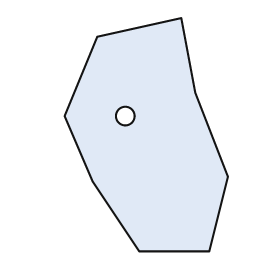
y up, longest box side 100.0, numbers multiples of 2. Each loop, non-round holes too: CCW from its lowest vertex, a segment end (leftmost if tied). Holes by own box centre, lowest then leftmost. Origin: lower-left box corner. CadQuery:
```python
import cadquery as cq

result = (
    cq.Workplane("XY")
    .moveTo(32.0, 0.0)
    .lineTo(62.0, 0.0)
    .lineTo(70.0, 32.0)
    .lineTo(56.0, 68.0)
    .lineTo(50.0, 100.0)
    .lineTo(14.0, 92.0)
    .lineTo(0.0, 58.0)
    .lineTo(12.0, 30.0)
    .close()
    .moveTo(26.0, 58.0)
    .circle(4.0)
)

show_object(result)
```